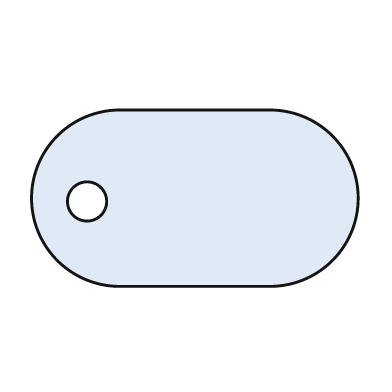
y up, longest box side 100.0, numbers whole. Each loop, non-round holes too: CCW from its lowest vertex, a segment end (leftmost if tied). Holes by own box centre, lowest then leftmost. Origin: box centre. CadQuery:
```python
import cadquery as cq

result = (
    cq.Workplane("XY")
    .moveTo(-23.0, -27.0)
    .lineTo(23.0, -27.0)
    .threePointArc((50.0, 0.0), (23.0, 27.0))
    .lineTo(-23.0, 27.0)
    .threePointArc((-50.0, 0.0), (-23.0, -27.0))
    .close()
    .moveTo(-33.0, -1.0)
    .circle(6.0)
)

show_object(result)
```